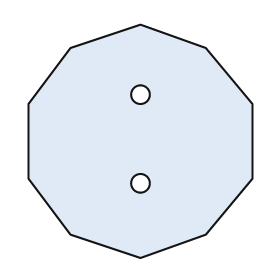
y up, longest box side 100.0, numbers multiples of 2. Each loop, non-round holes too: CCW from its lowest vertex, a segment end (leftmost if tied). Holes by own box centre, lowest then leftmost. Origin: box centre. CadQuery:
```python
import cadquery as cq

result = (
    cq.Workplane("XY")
    .moveTo(0.0, -50.0)
    .lineTo(28.0, -40.0)
    .lineTo(48.0, -16.0)
    .lineTo(48.0, 16.0)
    .lineTo(28.0, 40.0)
    .lineTo(0.0, 50.0)
    .lineTo(-30.0, 40.0)
    .lineTo(-48.0, 16.0)
    .lineTo(-48.0, -16.0)
    .lineTo(-30.0, -40.0)
    .close()
    .moveTo(0.0, -18.0)
    .circle(4.0)
    .moveTo(0.0, 20.0)
    .circle(4.0)
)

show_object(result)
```